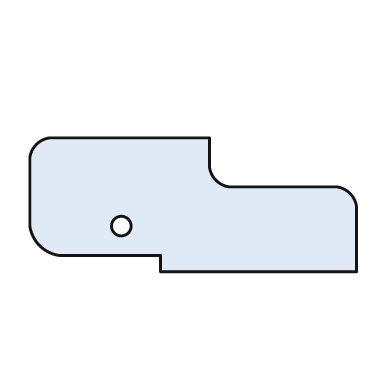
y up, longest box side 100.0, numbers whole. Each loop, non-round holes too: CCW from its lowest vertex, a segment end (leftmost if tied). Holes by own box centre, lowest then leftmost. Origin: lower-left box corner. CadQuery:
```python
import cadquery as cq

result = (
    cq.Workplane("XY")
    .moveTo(40.0, 0.0)
    .lineTo(100.0, 0.0)
    .lineTo(100.0, 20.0)
    .threePointArc((98.0, 24.0), (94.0, 26.0))
    .lineTo(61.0, 26.0)
    .threePointArc((57.0, 28.0), (55.0, 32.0))
    .lineTo(55.0, 41.0)
    .lineTo(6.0, 41.0)
    .threePointArc((2.0, 39.0), (0.0, 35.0))
    .lineTo(0.0, 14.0)
    .threePointArc((3.0, 8.0), (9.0, 5.0))
    .lineTo(40.0, 5.0)
    .close()
    .moveTo(28.0, 14.0)
    .circle(3.0)
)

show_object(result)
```